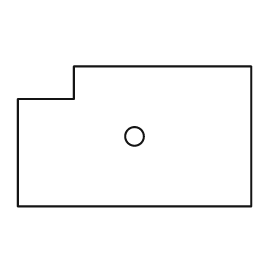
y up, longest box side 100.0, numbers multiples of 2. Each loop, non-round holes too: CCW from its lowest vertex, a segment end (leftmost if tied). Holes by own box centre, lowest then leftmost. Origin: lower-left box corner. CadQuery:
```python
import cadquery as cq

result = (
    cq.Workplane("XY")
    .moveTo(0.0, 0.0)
    .lineTo(100.0, 0.0)
    .lineTo(100.0, 60.0)
    .lineTo(24.0, 60.0)
    .lineTo(24.0, 46.0)
    .lineTo(0.0, 46.0)
    .close()
    .moveTo(50.0, 30.0)
    .circle(4.0)
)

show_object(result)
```